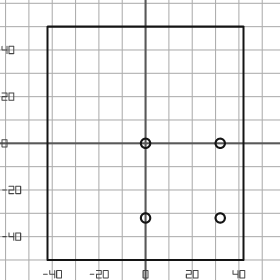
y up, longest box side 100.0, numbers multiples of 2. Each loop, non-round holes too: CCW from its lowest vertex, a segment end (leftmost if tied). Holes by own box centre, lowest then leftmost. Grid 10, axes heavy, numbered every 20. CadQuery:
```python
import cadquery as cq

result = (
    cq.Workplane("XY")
    .moveTo(-42.0, -50.0)
    .lineTo(42.0, -50.0)
    .lineTo(42.0, 50.0)
    .lineTo(-42.0, 50.0)
    .close()
    .moveTo(0.0, -32.0)
    .circle(2.0)
    .moveTo(32.0, -32.0)
    .circle(2.0)
    .moveTo(0.0, 0.0)
    .circle(2.0)
    .moveTo(32.0, 0.0)
    .circle(2.0)
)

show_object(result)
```